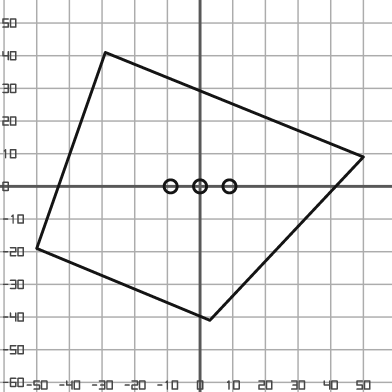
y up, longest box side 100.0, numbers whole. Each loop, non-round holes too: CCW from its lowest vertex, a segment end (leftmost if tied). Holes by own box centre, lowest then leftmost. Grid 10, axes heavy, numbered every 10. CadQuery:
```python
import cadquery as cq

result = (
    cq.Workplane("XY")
    .moveTo(3.0, -41.0)
    .lineTo(50.0, 9.0)
    .lineTo(-29.0, 41.0)
    .lineTo(-50.0, -19.0)
    .close()
    .moveTo(-9.0, 0.0)
    .circle(2.0)
    .moveTo(0.0, 0.0)
    .circle(2.0)
    .moveTo(9.0, 0.0)
    .circle(2.0)
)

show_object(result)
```